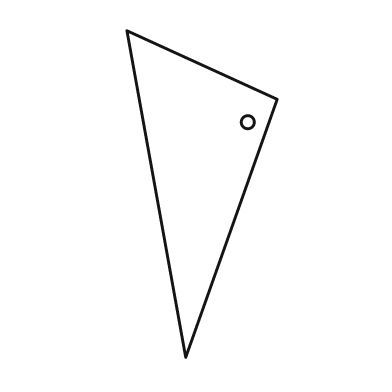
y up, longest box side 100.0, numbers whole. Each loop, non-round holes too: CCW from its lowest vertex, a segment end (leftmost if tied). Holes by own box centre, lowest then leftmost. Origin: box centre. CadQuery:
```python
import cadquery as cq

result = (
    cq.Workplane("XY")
    .moveTo(-5.0, -50.0)
    .lineTo(23.0, 29.0)
    .lineTo(-23.0, 50.0)
    .close()
    .moveTo(14.0, 22.0)
    .circle(2.0)
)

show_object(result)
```